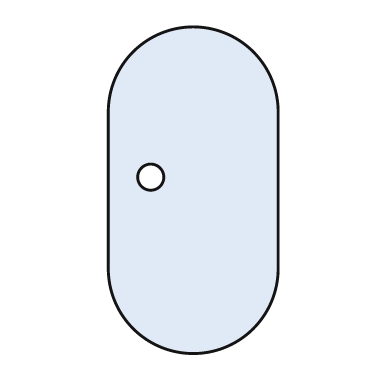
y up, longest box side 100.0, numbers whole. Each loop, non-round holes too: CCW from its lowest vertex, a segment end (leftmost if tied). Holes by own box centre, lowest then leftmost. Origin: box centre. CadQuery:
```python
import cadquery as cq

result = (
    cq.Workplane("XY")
    .moveTo(-26.0, -24.0)
    .threePointArc((0.0, -50.0), (26.0, -24.0))
    .lineTo(26.0, 24.0)
    .threePointArc((0.0, 50.0), (-26.0, 24.0))
    .close()
    .moveTo(-13.0, 4.0)
    .circle(4.0)
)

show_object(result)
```